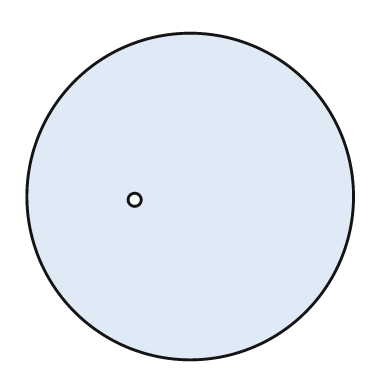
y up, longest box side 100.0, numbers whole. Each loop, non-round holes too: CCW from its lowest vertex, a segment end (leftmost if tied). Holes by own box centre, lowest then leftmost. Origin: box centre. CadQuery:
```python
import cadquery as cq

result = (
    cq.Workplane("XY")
    .moveTo(0.0, 0.0)
    .circle(50.0)
    .moveTo(-17.0, -1.0)
    .circle(2.0)
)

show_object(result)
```